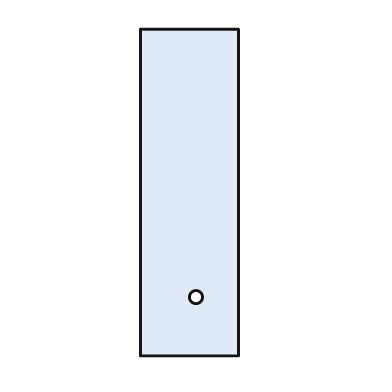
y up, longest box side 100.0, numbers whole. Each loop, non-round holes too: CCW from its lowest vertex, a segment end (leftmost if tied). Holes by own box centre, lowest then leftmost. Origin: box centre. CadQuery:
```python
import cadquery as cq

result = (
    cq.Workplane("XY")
    .moveTo(-15.0, -50.0)
    .lineTo(15.0, -50.0)
    .lineTo(15.0, 50.0)
    .lineTo(-15.0, 50.0)
    .close()
    .moveTo(2.0, -32.0)
    .circle(2.0)
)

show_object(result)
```